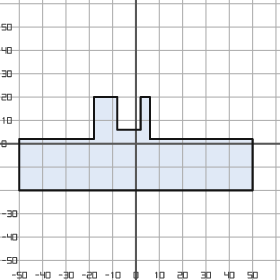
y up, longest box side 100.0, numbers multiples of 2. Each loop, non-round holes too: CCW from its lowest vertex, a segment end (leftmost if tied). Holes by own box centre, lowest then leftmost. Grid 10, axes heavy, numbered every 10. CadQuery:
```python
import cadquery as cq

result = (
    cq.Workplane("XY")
    .moveTo(-50.0, -20.0)
    .lineTo(50.0, -20.0)
    .lineTo(50.0, 2.0)
    .lineTo(6.0, 2.0)
    .lineTo(6.0, 20.0)
    .lineTo(2.0, 20.0)
    .lineTo(2.0, 6.0)
    .lineTo(-8.0, 6.0)
    .lineTo(-8.0, 20.0)
    .lineTo(-18.0, 20.0)
    .lineTo(-18.0, 2.0)
    .lineTo(-50.0, 2.0)
    .close()
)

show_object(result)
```